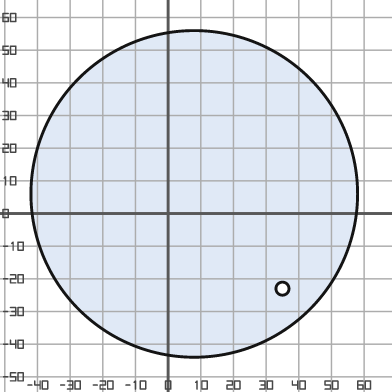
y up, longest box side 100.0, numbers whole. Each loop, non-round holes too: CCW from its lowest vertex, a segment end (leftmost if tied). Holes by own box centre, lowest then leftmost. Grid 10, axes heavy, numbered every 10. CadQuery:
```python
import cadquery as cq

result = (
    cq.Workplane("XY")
    .moveTo(8.0, 6.0)
    .circle(50.0)
    .moveTo(35.0, -23.0)
    .circle(2.0)
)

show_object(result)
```